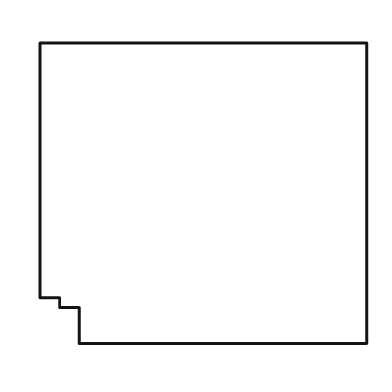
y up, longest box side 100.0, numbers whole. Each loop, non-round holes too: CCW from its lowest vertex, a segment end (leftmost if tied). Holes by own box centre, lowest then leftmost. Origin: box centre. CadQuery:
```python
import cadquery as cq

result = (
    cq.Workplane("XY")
    .moveTo(-38.0, -46.0)
    .lineTo(50.0, -46.0)
    .lineTo(50.0, 46.0)
    .lineTo(-50.0, 46.0)
    .lineTo(-50.0, -32.0)
    .lineTo(-44.0, -32.0)
    .lineTo(-44.0, -35.0)
    .lineTo(-38.0, -35.0)
    .close()
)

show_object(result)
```